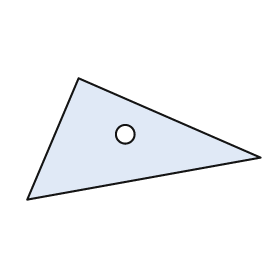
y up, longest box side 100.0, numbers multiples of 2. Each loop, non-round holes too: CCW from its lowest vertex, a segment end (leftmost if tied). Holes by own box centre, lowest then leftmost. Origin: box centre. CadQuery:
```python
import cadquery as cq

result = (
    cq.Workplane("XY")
    .moveTo(-50.0, -26.0)
    .lineTo(50.0, -8.0)
    .lineTo(-28.0, 26.0)
    .close()
    .moveTo(-8.0, 2.0)
    .circle(4.0)
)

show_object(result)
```